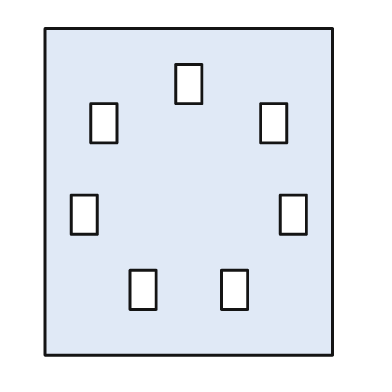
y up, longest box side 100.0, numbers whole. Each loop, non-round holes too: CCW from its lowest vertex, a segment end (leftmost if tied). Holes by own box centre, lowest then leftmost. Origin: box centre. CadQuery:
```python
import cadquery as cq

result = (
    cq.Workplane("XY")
    .moveTo(-44.0, -50.0)
    .lineTo(44.0, -50.0)
    .lineTo(44.0, 50.0)
    .lineTo(-44.0, 50.0)
    .close()
    .moveTo(-18.0, -36.0)
    .lineTo(-10.0, -36.0)
    .lineTo(-10.0, -24.0)
    .lineTo(-18.0, -24.0)
    .close()
    .moveTo(10.0, -36.0)
    .lineTo(18.0, -36.0)
    .lineTo(18.0, -24.0)
    .lineTo(10.0, -24.0)
    .close()
    .moveTo(-36.0, -13.0)
    .lineTo(-28.0, -13.0)
    .lineTo(-28.0, -1.0)
    .lineTo(-36.0, -1.0)
    .close()
    .moveTo(28.0, -13.0)
    .lineTo(36.0, -13.0)
    .lineTo(36.0, -1.0)
    .lineTo(28.0, -1.0)
    .close()
    .moveTo(-30.0, 15.0)
    .lineTo(-22.0, 15.0)
    .lineTo(-22.0, 27.0)
    .lineTo(-30.0, 27.0)
    .close()
    .moveTo(22.0, 15.0)
    .lineTo(30.0, 15.0)
    .lineTo(30.0, 27.0)
    .lineTo(22.0, 27.0)
    .close()
    .moveTo(-4.0, 27.0)
    .lineTo(4.0, 27.0)
    .lineTo(4.0, 39.0)
    .lineTo(-4.0, 39.0)
    .close()
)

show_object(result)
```